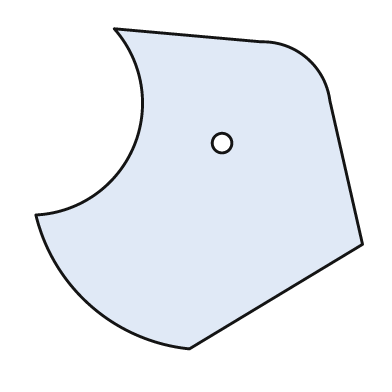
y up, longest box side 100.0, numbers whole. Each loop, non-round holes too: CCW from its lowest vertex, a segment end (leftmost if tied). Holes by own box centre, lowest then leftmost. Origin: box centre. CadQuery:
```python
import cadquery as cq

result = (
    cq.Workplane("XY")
    .moveTo(-3.0, -49.0)
    .lineTo(50.0, -17.0)
    .lineTo(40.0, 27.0)
    .threePointArc((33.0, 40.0), (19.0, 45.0))
    .lineTo(-26.0, 49.0)
    .threePointArc((-20.0, 13.0), (-50.0, -8.0))
    .threePointArc((-33.0, -36.0), (-3.0, -49.0))
    .close()
    .moveTo(7.0, 14.0)
    .circle(3.0)
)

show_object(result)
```